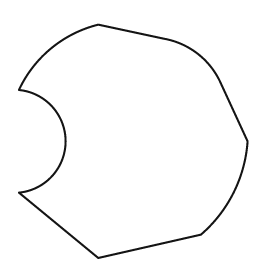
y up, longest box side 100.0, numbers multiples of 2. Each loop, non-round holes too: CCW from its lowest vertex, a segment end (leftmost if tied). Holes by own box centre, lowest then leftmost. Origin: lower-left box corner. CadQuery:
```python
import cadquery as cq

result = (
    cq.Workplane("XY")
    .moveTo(34.0, 0.0)
    .lineTo(78.0, 10.0)
    .threePointArc((92.0, 28.0), (98.0, 50.0))
    .lineTo(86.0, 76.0)
    .threePointArc((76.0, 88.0), (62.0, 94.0))
    .lineTo(34.0, 100.0)
    .threePointArc((14.0, 90.0), (0.0, 72.0))
    .threePointArc((20.0, 50.0), (0.0, 28.0))
    .close()
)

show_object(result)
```